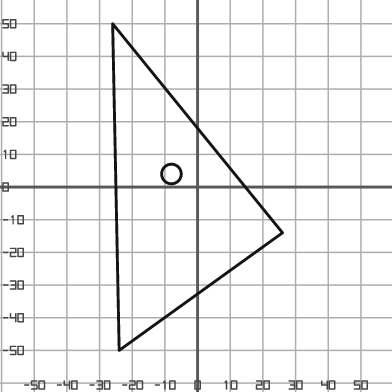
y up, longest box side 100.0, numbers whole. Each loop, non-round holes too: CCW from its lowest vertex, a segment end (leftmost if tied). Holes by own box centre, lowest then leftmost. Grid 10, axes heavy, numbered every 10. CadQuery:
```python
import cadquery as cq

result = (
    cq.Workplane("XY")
    .moveTo(-24.0, -50.0)
    .lineTo(26.0, -14.0)
    .lineTo(-26.0, 50.0)
    .close()
    .moveTo(-8.0, 4.0)
    .circle(3.0)
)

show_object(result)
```